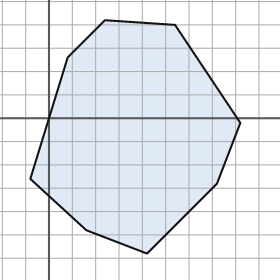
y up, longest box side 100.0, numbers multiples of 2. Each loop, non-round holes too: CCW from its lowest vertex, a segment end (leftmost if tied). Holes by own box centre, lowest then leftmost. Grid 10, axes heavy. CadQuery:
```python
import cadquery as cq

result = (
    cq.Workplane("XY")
    .moveTo(42.0, -58.0)
    .lineTo(72.0, -28.0)
    .lineTo(82.0, -2.0)
    .lineTo(54.0, 40.0)
    .lineTo(24.0, 42.0)
    .lineTo(8.0, 26.0)
    .lineTo(-8.0, -26.0)
    .lineTo(16.0, -48.0)
    .close()
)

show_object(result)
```